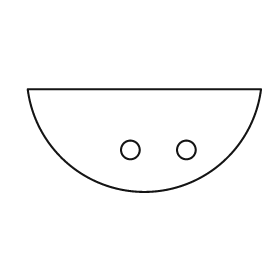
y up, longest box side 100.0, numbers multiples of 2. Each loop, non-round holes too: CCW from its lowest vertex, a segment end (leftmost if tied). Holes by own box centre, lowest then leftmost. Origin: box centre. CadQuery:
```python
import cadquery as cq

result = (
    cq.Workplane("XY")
    .moveTo(-50.0, 22.0)
    .threePointArc((0.0, -22.0), (50.0, 22.0))
    .close()
    .moveTo(-6.0, -4.0)
    .circle(4.0)
    .moveTo(18.0, -4.0)
    .circle(4.0)
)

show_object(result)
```